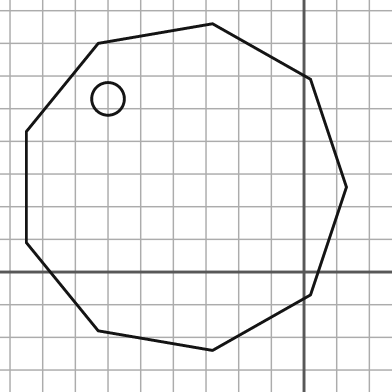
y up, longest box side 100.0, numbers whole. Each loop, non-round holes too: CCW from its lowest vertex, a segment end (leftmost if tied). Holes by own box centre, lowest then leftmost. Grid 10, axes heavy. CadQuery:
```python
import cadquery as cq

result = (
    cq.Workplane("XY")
    .moveTo(-28.0, -24.0)
    .lineTo(2.0, -7.0)
    .lineTo(13.0, 26.0)
    .lineTo(2.0, 59.0)
    .lineTo(-28.0, 76.0)
    .lineTo(-63.0, 70.0)
    .lineTo(-85.0, 43.0)
    .lineTo(-85.0, 9.0)
    .lineTo(-63.0, -18.0)
    .close()
    .moveTo(-60.0, 53.0)
    .circle(5.0)
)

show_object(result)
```